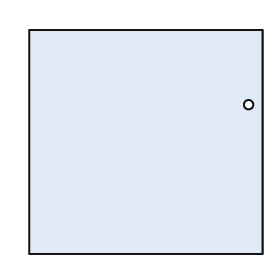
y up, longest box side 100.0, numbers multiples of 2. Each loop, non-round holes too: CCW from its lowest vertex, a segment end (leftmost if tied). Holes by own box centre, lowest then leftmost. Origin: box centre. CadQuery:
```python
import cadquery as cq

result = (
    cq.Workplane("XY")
    .moveTo(-50.0, -48.0)
    .lineTo(50.0, -48.0)
    .lineTo(50.0, 48.0)
    .lineTo(-50.0, 48.0)
    .close()
    .moveTo(44.0, 16.0)
    .circle(2.0)
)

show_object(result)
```